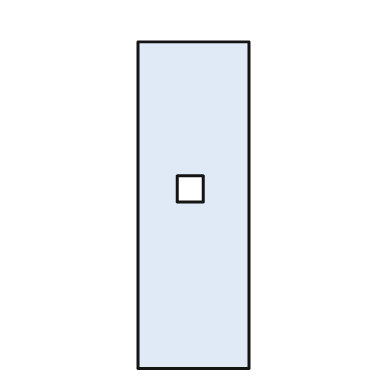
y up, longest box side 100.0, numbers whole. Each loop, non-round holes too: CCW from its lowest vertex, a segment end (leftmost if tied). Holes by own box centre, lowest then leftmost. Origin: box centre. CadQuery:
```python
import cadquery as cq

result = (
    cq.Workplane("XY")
    .moveTo(-17.0, -50.0)
    .lineTo(17.0, -50.0)
    .lineTo(17.0, 50.0)
    .lineTo(-17.0, 50.0)
    .close()
    .moveTo(-5.0, 1.0)
    .lineTo(3.0, 1.0)
    .lineTo(3.0, 9.0)
    .lineTo(-5.0, 9.0)
    .close()
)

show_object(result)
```